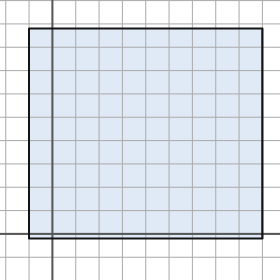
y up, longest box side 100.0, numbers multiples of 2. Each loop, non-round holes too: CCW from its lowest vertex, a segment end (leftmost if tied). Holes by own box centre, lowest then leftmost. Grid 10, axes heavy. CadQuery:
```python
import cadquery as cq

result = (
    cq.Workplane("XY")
    .moveTo(-10.0, -2.0)
    .lineTo(90.0, -2.0)
    .lineTo(90.0, 88.0)
    .lineTo(-10.0, 88.0)
    .close()
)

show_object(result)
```